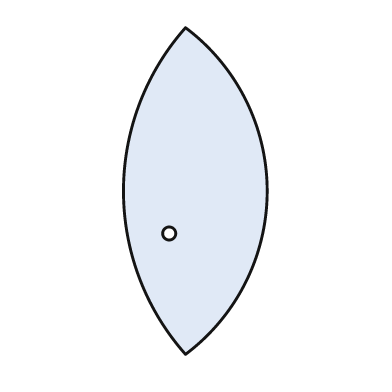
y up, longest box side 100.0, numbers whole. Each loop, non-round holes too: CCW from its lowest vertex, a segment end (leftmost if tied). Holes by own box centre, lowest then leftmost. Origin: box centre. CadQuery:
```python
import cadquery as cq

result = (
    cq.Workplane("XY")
    .moveTo(-3.0, -50.0)
    .threePointArc((22.0, 0.0), (-3.0, 50.0))
    .threePointArc((-22.0, 0.0), (-3.0, -50.0))
    .close()
    .moveTo(-8.0, -13.0)
    .circle(2.0)
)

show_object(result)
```